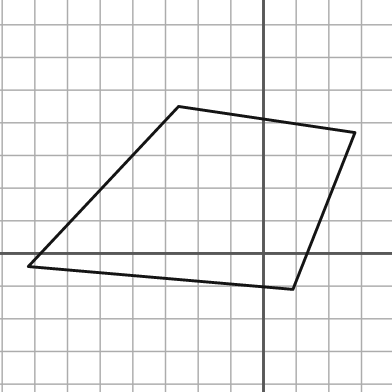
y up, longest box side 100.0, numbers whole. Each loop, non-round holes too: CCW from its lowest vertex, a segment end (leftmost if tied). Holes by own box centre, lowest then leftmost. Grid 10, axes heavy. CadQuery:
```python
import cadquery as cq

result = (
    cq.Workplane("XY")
    .moveTo(9.0, -11.0)
    .lineTo(28.0, 37.0)
    .lineTo(-26.0, 45.0)
    .lineTo(-72.0, -4.0)
    .close()
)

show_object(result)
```